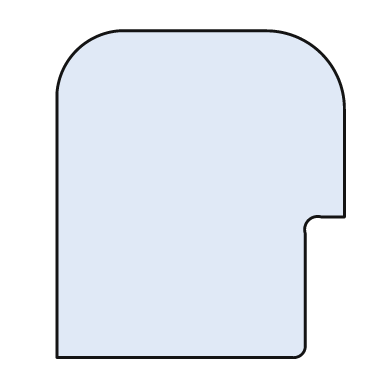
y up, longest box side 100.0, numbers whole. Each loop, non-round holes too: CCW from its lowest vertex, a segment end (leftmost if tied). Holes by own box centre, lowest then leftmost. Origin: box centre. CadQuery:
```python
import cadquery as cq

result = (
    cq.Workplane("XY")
    .moveTo(-44.0, -50.0)
    .lineTo(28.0, -50.0)
    .threePointArc((31.0, -49.0), (32.0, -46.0))
    .lineTo(32.0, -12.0)
    .threePointArc((33.0, -8.0), (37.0, -7.0))
    .lineTo(44.0, -7.0)
    .lineTo(44.0, 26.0)
    .threePointArc((37.0, 43.0), (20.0, 50.0))
    .lineTo(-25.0, 50.0)
    .threePointArc((-38.0, 44.0), (-44.0, 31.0))
    .close()
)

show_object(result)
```